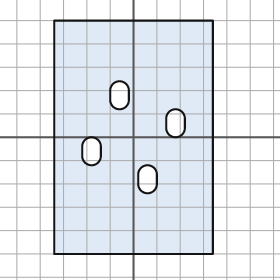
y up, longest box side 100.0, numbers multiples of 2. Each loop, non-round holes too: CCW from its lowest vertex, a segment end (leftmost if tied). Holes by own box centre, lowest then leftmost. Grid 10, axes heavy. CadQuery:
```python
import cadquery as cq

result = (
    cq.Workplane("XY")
    .moveTo(-34.0, -50.0)
    .lineTo(34.0, -50.0)
    .lineTo(34.0, 50.0)
    .lineTo(-34.0, 50.0)
    .close()
    .moveTo(2.0, -20.0)
    .threePointArc((6.0, -24.0), (10.0, -20.0))
    .lineTo(10.0, -16.0)
    .threePointArc((6.0, -12.0), (2.0, -16.0))
    .close()
    .moveTo(-22.0, -8.0)
    .threePointArc((-18.0, -12.0), (-14.0, -8.0))
    .lineTo(-14.0, -4.0)
    .threePointArc((-18.0, 0.0), (-22.0, -4.0))
    .close()
    .moveTo(14.0, 4.0)
    .threePointArc((18.0, 0.0), (22.0, 4.0))
    .lineTo(22.0, 8.0)
    .threePointArc((18.0, 12.0), (14.0, 8.0))
    .close()
    .moveTo(-10.0, 16.0)
    .threePointArc((-6.0, 12.0), (-2.0, 16.0))
    .lineTo(-2.0, 20.0)
    .threePointArc((-6.0, 24.0), (-10.0, 20.0))
    .close()
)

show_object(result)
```